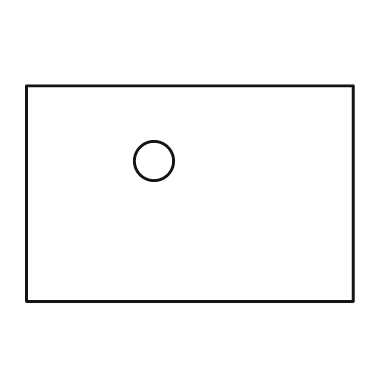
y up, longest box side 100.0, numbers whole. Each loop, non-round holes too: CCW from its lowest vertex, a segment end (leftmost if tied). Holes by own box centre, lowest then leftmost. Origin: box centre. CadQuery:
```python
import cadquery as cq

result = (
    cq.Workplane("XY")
    .moveTo(-50.0, -33.0)
    .lineTo(50.0, -33.0)
    .lineTo(50.0, 33.0)
    .lineTo(-50.0, 33.0)
    .close()
    .moveTo(-11.0, 10.0)
    .circle(6.0)
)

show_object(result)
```